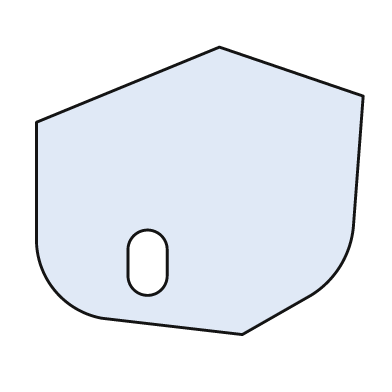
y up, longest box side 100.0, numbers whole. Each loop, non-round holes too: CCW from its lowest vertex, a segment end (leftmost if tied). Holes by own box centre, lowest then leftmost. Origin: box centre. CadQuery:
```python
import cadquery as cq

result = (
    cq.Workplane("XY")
    .moveTo(13.0, -44.0)
    .lineTo(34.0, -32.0)
    .threePointArc((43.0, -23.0), (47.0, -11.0))
    .lineTo(50.0, 29.0)
    .lineTo(6.0, 44.0)
    .lineTo(-50.0, 21.0)
    .lineTo(-50.0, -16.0)
    .threePointArc((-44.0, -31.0), (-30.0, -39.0))
    .close()
    .moveTo(-22.0, -26.0)
    .threePointArc((-16.0, -32.0), (-10.0, -26.0))
    .lineTo(-10.0, -18.0)
    .threePointArc((-16.0, -12.0), (-22.0, -18.0))
    .close()
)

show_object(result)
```